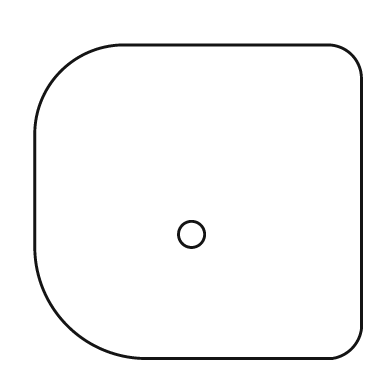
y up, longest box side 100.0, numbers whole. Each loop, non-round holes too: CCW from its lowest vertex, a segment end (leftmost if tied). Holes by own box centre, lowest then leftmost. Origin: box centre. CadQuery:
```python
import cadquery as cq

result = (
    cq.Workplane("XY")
    .moveTo(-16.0, -48.0)
    .lineTo(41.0, -48.0)
    .threePointArc((47.0, -45.0), (50.0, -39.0))
    .lineTo(50.0, 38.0)
    .threePointArc((47.0, 45.0), (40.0, 48.0))
    .lineTo(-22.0, 48.0)
    .threePointArc((-42.0, 40.0), (-50.0, 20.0))
    .lineTo(-50.0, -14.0)
    .threePointArc((-40.0, -38.0), (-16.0, -48.0))
    .close()
    .moveTo(-2.0, -10.0)
    .circle(4.0)
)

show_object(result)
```